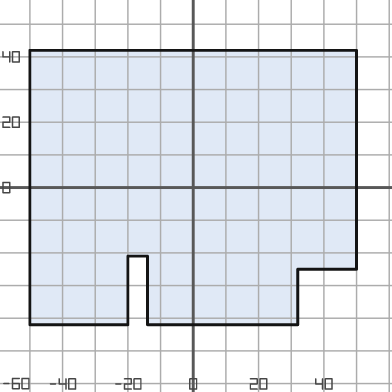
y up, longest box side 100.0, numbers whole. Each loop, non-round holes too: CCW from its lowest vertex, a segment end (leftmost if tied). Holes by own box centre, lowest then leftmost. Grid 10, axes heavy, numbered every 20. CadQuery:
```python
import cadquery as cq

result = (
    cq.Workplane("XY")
    .moveTo(-50.0, -42.0)
    .lineTo(-20.0, -42.0)
    .lineTo(-20.0, -21.0)
    .lineTo(-14.0, -21.0)
    .lineTo(-14.0, -42.0)
    .lineTo(32.0, -42.0)
    .lineTo(32.0, -25.0)
    .lineTo(50.0, -25.0)
    .lineTo(50.0, 42.0)
    .lineTo(-50.0, 42.0)
    .close()
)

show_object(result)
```